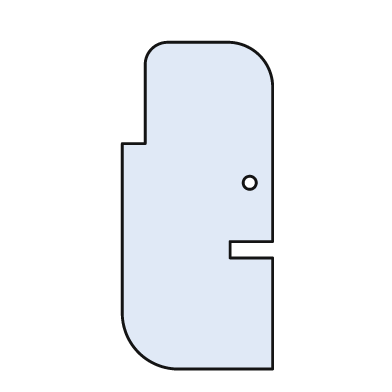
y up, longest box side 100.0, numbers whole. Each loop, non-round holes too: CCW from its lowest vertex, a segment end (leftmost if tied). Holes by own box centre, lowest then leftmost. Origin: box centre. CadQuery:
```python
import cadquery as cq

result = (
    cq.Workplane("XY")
    .moveTo(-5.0, -50.0)
    .lineTo(23.0, -50.0)
    .lineTo(23.0, -16.0)
    .lineTo(10.0, -16.0)
    .lineTo(10.0, -11.0)
    .lineTo(23.0, -11.0)
    .lineTo(23.0, 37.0)
    .threePointArc((19.0, 46.0), (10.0, 50.0))
    .lineTo(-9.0, 50.0)
    .threePointArc((-14.0, 48.0), (-16.0, 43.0))
    .lineTo(-16.0, 19.0)
    .lineTo(-23.0, 19.0)
    .lineTo(-23.0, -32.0)
    .threePointArc((-18.0, -45.0), (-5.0, -50.0))
    .close()
    .moveTo(16.0, 7.0)
    .circle(2.0)
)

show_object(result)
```